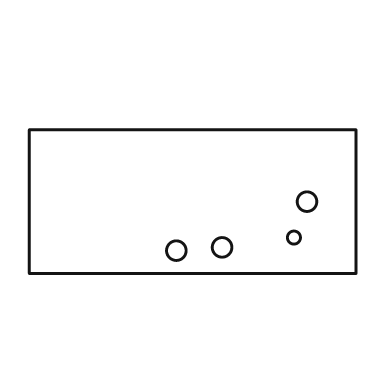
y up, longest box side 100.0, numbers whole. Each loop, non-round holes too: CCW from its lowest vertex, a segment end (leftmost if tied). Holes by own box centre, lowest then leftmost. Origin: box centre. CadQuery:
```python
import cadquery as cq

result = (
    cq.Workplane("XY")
    .moveTo(-50.0, -22.0)
    .lineTo(50.0, -22.0)
    .lineTo(50.0, 22.0)
    .lineTo(-50.0, 22.0)
    .close()
    .moveTo(-5.0, -15.0)
    .circle(3.0)
    .moveTo(9.0, -14.0)
    .circle(3.0)
    .moveTo(31.0, -11.0)
    .circle(2.0)
    .moveTo(35.0, 0.0)
    .circle(3.0)
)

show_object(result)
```